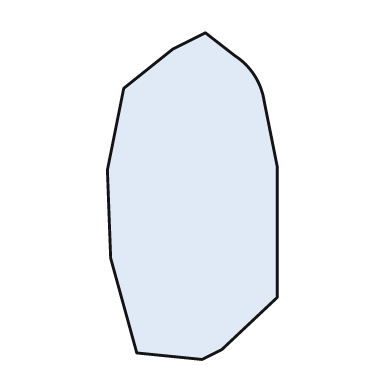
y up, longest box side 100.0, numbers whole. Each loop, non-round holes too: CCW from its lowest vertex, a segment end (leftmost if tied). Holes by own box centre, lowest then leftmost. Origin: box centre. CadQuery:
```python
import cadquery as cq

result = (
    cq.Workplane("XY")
    .moveTo(3.0, -50.0)
    .lineTo(9.0, -47.0)
    .lineTo(26.0, -31.0)
    .lineTo(26.0, 9.0)
    .lineTo(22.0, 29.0)
    .threePointArc((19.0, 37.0), (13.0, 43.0))
    .lineTo(4.0, 50.0)
    .lineTo(-6.0, 45.0)
    .lineTo(-21.0, 33.0)
    .lineTo(-26.0, 8.0)
    .lineTo(-25.0, -19.0)
    .lineTo(-17.0, -48.0)
    .close()
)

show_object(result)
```